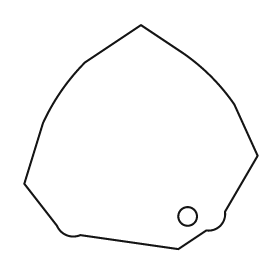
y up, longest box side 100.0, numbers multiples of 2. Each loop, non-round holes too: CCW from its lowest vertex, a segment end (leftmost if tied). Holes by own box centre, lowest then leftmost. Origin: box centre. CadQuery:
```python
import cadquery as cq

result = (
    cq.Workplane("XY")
    .moveTo(16.0, -48.0)
    .lineTo(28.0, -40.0)
    .threePointArc((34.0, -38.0), (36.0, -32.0))
    .lineTo(50.0, -8.0)
    .lineTo(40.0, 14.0)
    .threePointArc((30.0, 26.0), (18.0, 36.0))
    .lineTo(0.0, 48.0)
    .lineTo(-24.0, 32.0)
    .threePointArc((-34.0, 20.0), (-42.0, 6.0))
    .lineTo(-50.0, -20.0)
    .lineTo(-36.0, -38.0)
    .threePointArc((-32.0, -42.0), (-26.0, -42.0))
    .close()
    .moveTo(20.0, -34.0)
    .circle(4.0)
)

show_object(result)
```